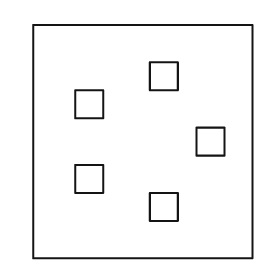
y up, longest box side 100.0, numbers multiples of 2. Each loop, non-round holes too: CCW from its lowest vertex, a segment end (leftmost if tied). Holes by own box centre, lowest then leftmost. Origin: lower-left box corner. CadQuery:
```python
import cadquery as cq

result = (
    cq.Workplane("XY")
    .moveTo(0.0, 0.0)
    .lineTo(94.0, 0.0)
    .lineTo(94.0, 100.0)
    .lineTo(0.0, 100.0)
    .close()
    .moveTo(50.0, 16.0)
    .lineTo(62.0, 16.0)
    .lineTo(62.0, 28.0)
    .lineTo(50.0, 28.0)
    .close()
    .moveTo(18.0, 28.0)
    .lineTo(30.0, 28.0)
    .lineTo(30.0, 40.0)
    .lineTo(18.0, 40.0)
    .close()
    .moveTo(70.0, 44.0)
    .lineTo(82.0, 44.0)
    .lineTo(82.0, 56.0)
    .lineTo(70.0, 56.0)
    .close()
    .moveTo(18.0, 60.0)
    .lineTo(30.0, 60.0)
    .lineTo(30.0, 72.0)
    .lineTo(18.0, 72.0)
    .close()
    .moveTo(50.0, 72.0)
    .lineTo(62.0, 72.0)
    .lineTo(62.0, 84.0)
    .lineTo(50.0, 84.0)
    .close()
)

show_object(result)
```